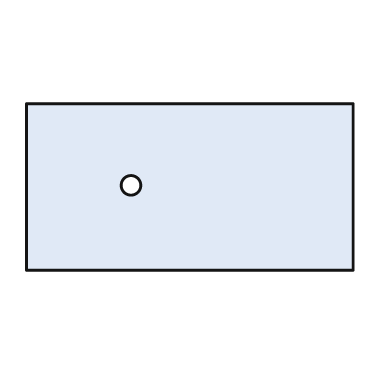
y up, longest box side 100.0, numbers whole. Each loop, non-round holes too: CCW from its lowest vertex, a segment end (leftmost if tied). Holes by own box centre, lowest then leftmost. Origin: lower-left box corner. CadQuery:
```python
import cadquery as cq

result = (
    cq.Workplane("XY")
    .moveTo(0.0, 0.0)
    .lineTo(100.0, 0.0)
    .lineTo(100.0, 51.0)
    .lineTo(0.0, 51.0)
    .close()
    .moveTo(32.0, 26.0)
    .circle(3.0)
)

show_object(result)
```